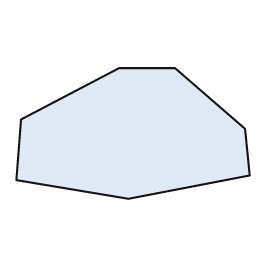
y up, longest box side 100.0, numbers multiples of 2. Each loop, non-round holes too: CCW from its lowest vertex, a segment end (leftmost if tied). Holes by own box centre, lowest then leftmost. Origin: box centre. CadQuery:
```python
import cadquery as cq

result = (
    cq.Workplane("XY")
    .moveTo(-2.0, -28.0)
    .lineTo(50.0, -18.0)
    .lineTo(48.0, 2.0)
    .lineTo(18.0, 28.0)
    .lineTo(-6.0, 28.0)
    .lineTo(-48.0, 6.0)
    .lineTo(-50.0, -20.0)
    .close()
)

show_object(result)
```